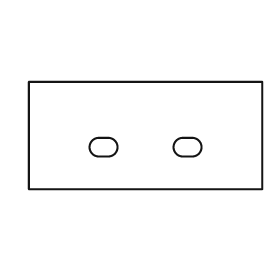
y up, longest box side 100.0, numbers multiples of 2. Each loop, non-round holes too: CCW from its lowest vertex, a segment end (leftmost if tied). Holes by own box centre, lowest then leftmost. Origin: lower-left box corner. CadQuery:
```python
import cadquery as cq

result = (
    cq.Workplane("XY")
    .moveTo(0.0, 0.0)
    .lineTo(100.0, 0.0)
    .lineTo(100.0, 46.0)
    .lineTo(0.0, 46.0)
    .close()
    .moveTo(30.0, 14.0)
    .lineTo(34.0, 14.0)
    .threePointArc((38.0, 18.0), (34.0, 22.0))
    .lineTo(30.0, 22.0)
    .threePointArc((26.0, 18.0), (30.0, 14.0))
    .close()
    .moveTo(66.0, 14.0)
    .lineTo(70.0, 14.0)
    .threePointArc((74.0, 18.0), (70.0, 22.0))
    .lineTo(66.0, 22.0)
    .threePointArc((62.0, 18.0), (66.0, 14.0))
    .close()
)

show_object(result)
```